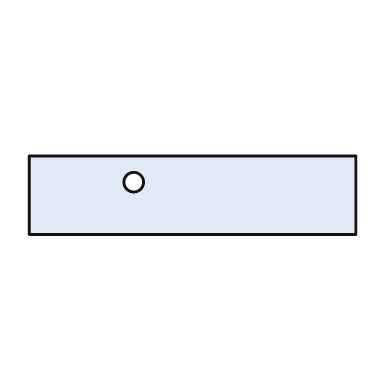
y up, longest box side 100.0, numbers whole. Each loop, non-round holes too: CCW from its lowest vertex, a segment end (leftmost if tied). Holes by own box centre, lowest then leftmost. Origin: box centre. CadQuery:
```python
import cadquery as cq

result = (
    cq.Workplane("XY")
    .moveTo(-50.0, -12.0)
    .lineTo(50.0, -12.0)
    .lineTo(50.0, 12.0)
    .lineTo(-50.0, 12.0)
    .close()
    .moveTo(-18.0, 4.0)
    .circle(3.0)
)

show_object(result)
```